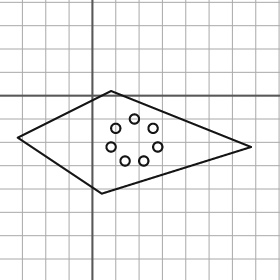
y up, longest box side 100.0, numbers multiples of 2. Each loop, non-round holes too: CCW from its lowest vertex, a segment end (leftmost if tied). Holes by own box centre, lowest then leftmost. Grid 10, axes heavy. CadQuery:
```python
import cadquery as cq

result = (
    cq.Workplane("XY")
    .moveTo(4.0, -42.0)
    .lineTo(68.0, -22.0)
    .lineTo(8.0, 2.0)
    .lineTo(-32.0, -18.0)
    .close()
    .moveTo(14.0, -28.0)
    .circle(2.0)
    .moveTo(22.0, -28.0)
    .circle(2.0)
    .moveTo(8.0, -22.0)
    .circle(2.0)
    .moveTo(28.0, -22.0)
    .circle(2.0)
    .moveTo(10.0, -14.0)
    .circle(2.0)
    .moveTo(26.0, -14.0)
    .circle(2.0)
    .moveTo(18.0, -10.0)
    .circle(2.0)
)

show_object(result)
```